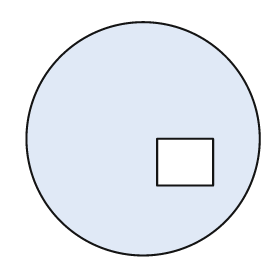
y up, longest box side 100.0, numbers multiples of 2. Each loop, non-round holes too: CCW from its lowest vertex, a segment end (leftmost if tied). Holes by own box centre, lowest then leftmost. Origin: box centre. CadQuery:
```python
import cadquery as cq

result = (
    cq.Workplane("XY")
    .moveTo(0.0, 0.0)
    .circle(50.0)
    .moveTo(6.0, -20.0)
    .lineTo(30.0, -20.0)
    .lineTo(30.0, 0.0)
    .lineTo(6.0, 0.0)
    .close()
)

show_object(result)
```